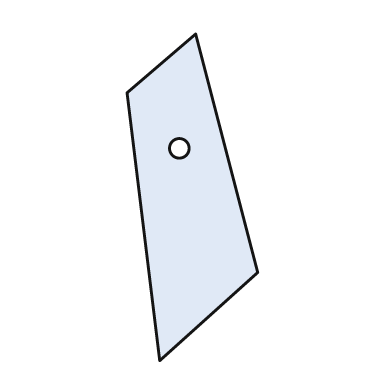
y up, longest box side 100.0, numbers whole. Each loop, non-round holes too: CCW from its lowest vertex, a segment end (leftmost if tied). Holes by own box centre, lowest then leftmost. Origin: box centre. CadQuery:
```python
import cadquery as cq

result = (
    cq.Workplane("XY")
    .moveTo(-10.0, -50.0)
    .lineTo(20.0, -23.0)
    .lineTo(1.0, 50.0)
    .lineTo(-20.0, 32.0)
    .close()
    .moveTo(-4.0, 15.0)
    .circle(3.0)
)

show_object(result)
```